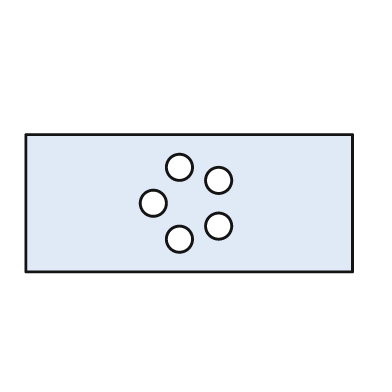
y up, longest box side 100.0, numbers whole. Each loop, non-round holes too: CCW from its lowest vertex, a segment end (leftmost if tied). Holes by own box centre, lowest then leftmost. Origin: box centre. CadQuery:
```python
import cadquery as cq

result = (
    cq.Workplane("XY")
    .moveTo(-50.0, -21.0)
    .lineTo(50.0, -21.0)
    .lineTo(50.0, 21.0)
    .lineTo(-50.0, 21.0)
    .close()
    .moveTo(-3.0, -11.0)
    .circle(4.0)
    .moveTo(9.0, -7.0)
    .circle(4.0)
    .moveTo(-11.0, 0.0)
    .circle(4.0)
    .moveTo(9.0, 7.0)
    .circle(4.0)
    .moveTo(-3.0, 11.0)
    .circle(4.0)
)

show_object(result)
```